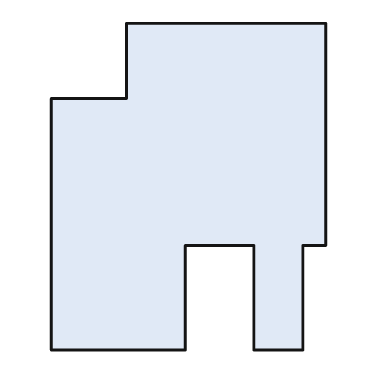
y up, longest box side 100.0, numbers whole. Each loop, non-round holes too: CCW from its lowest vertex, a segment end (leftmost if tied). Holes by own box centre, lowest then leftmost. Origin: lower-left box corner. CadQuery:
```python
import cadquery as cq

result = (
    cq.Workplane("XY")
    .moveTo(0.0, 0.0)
    .lineTo(41.0, 0.0)
    .lineTo(41.0, 32.0)
    .lineTo(62.0, 32.0)
    .lineTo(62.0, 0.0)
    .lineTo(77.0, 0.0)
    .lineTo(77.0, 32.0)
    .lineTo(84.0, 32.0)
    .lineTo(84.0, 100.0)
    .lineTo(23.0, 100.0)
    .lineTo(23.0, 77.0)
    .lineTo(0.0, 77.0)
    .close()
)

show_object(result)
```